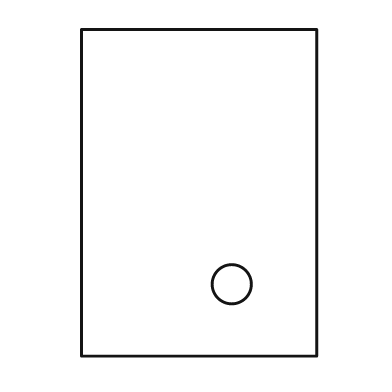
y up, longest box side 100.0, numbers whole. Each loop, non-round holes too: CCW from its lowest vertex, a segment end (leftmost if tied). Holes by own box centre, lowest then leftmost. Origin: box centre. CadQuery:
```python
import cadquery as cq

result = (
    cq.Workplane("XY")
    .moveTo(-36.0, -50.0)
    .lineTo(36.0, -50.0)
    .lineTo(36.0, 50.0)
    .lineTo(-36.0, 50.0)
    .close()
    .moveTo(10.0, -28.0)
    .circle(6.0)
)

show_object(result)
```